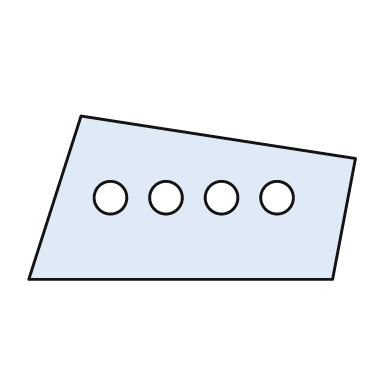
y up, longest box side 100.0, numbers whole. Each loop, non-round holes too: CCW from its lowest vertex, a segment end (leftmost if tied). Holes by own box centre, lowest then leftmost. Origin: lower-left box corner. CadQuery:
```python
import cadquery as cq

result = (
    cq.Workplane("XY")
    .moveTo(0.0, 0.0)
    .lineTo(93.0, 0.0)
    .lineTo(100.0, 37.0)
    .lineTo(16.0, 50.0)
    .close()
    .moveTo(25.0, 25.0)
    .circle(5.0)
    .moveTo(42.0, 25.0)
    .circle(5.0)
    .moveTo(59.0, 25.0)
    .circle(5.0)
    .moveTo(76.0, 25.0)
    .circle(5.0)
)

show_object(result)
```